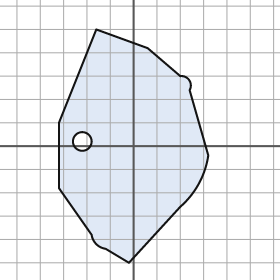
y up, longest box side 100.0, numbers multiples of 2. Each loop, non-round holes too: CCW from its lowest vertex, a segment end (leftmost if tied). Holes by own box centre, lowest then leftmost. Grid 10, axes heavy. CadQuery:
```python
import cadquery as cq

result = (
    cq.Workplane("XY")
    .moveTo(-2.0, -50.0)
    .lineTo(20.0, -26.0)
    .threePointArc((28.0, -16.0), (32.0, -4.0))
    .lineTo(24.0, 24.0)
    .threePointArc((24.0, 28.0), (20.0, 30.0))
    .lineTo(6.0, 42.0)
    .lineTo(-16.0, 50.0)
    .lineTo(-32.0, 10.0)
    .lineTo(-32.0, -18.0)
    .lineTo(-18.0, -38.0)
    .threePointArc((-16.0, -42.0), (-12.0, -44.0))
    .close()
    .moveTo(-22.0, 2.0)
    .circle(4.0)
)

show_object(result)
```